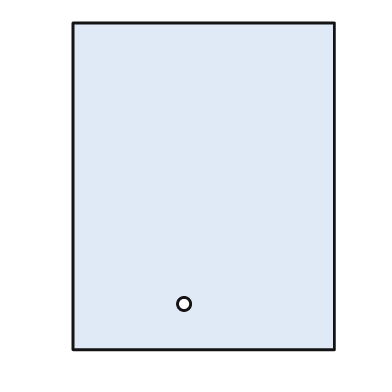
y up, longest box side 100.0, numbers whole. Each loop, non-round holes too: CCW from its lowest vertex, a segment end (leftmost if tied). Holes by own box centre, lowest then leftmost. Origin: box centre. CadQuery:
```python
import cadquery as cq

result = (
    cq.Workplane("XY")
    .moveTo(-40.0, -50.0)
    .lineTo(40.0, -50.0)
    .lineTo(40.0, 50.0)
    .lineTo(-40.0, 50.0)
    .close()
    .moveTo(-6.0, -36.0)
    .circle(2.0)
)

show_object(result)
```